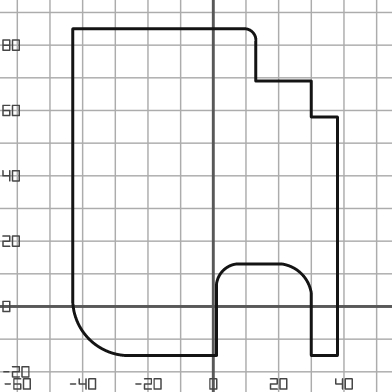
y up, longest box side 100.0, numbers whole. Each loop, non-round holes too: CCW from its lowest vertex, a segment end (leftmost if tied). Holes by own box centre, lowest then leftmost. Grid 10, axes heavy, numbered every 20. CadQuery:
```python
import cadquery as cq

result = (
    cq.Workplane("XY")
    .moveTo(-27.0, -15.0)
    .lineTo(1.0, -15.0)
    .lineTo(1.0, 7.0)
    .threePointArc((3.0, 11.0), (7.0, 13.0))
    .lineTo(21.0, 13.0)
    .threePointArc((27.0, 10.0), (30.0, 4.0))
    .lineTo(30.0, -15.0)
    .lineTo(38.0, -15.0)
    .lineTo(38.0, 58.0)
    .lineTo(30.0, 58.0)
    .lineTo(30.0, 69.0)
    .lineTo(13.0, 69.0)
    .lineTo(13.0, 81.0)
    .threePointArc((12.0, 84.0), (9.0, 85.0))
    .lineTo(-43.0, 85.0)
    .lineTo(-43.0, 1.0)
    .threePointArc((-38.0, -10.0), (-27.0, -15.0))
    .close()
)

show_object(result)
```